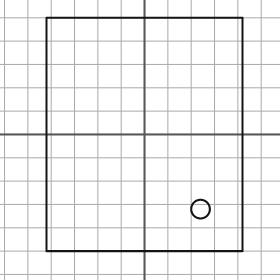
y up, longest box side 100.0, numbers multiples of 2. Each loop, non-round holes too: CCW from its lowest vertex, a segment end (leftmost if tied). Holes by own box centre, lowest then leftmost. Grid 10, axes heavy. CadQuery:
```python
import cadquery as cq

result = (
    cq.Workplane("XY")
    .moveTo(-42.0, -50.0)
    .lineTo(42.0, -50.0)
    .lineTo(42.0, 50.0)
    .lineTo(-42.0, 50.0)
    .close()
    .moveTo(24.0, -32.0)
    .circle(4.0)
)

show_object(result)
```